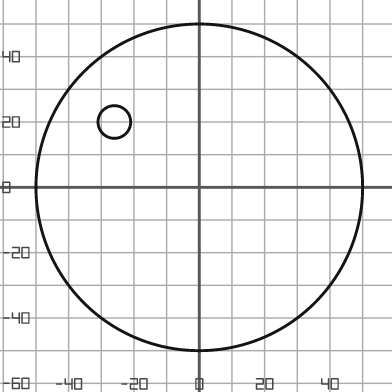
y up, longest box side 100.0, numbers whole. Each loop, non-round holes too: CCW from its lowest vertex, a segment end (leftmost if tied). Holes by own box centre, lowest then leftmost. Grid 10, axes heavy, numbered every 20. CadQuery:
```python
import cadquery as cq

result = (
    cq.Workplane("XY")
    .moveTo(0.0, 0.0)
    .circle(50.0)
    .moveTo(-26.0, 20.0)
    .circle(5.0)
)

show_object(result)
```